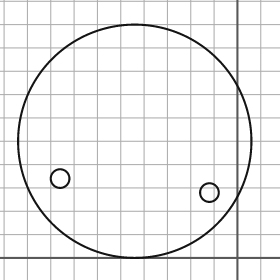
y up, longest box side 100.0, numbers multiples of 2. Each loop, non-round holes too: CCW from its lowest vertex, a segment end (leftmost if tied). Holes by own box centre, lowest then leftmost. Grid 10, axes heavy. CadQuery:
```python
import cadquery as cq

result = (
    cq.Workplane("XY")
    .moveTo(-44.0, 50.0)
    .circle(50.0)
    .moveTo(-12.0, 28.0)
    .circle(4.0)
    .moveTo(-76.0, 34.0)
    .circle(4.0)
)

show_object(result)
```